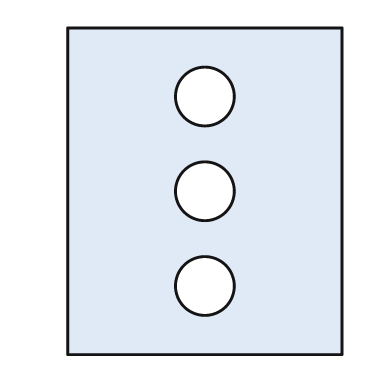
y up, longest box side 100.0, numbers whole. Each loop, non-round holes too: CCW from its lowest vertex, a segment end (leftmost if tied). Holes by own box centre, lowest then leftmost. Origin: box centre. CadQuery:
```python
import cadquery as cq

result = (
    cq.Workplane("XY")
    .moveTo(-42.0, -50.0)
    .lineTo(42.0, -50.0)
    .lineTo(42.0, 50.0)
    .lineTo(-42.0, 50.0)
    .close()
    .moveTo(0.0, -29.0)
    .circle(9.0)
    .moveTo(0.0, 0.0)
    .circle(9.0)
    .moveTo(0.0, 29.0)
    .circle(9.0)
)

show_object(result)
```